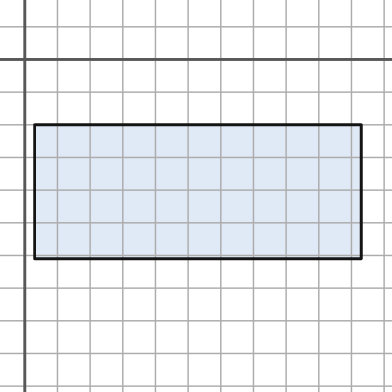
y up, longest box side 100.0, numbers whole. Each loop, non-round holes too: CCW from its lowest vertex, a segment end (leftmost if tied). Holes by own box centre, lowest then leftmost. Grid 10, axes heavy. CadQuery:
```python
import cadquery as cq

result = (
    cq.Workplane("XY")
    .moveTo(3.0, -61.0)
    .lineTo(103.0, -61.0)
    .lineTo(103.0, -20.0)
    .lineTo(3.0, -20.0)
    .close()
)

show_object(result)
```